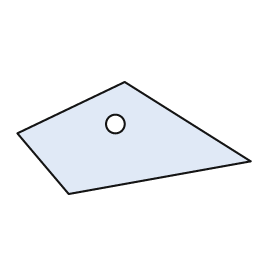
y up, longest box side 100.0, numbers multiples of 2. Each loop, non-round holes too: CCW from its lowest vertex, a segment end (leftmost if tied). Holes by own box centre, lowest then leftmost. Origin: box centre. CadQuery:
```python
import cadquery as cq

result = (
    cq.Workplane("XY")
    .moveTo(-28.0, -24.0)
    .lineTo(50.0, -10.0)
    .lineTo(-4.0, 24.0)
    .lineTo(-50.0, 2.0)
    .close()
    .moveTo(-8.0, 6.0)
    .circle(4.0)
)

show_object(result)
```